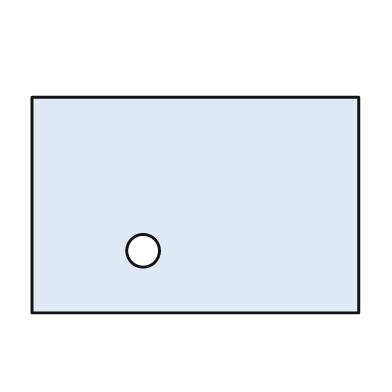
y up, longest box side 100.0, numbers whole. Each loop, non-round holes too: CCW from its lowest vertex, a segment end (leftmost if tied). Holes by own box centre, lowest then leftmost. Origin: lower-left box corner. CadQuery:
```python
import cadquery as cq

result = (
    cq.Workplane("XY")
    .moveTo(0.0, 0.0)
    .lineTo(100.0, 0.0)
    .lineTo(100.0, 66.0)
    .lineTo(0.0, 66.0)
    .close()
    .moveTo(34.0, 19.0)
    .circle(5.0)
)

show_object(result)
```